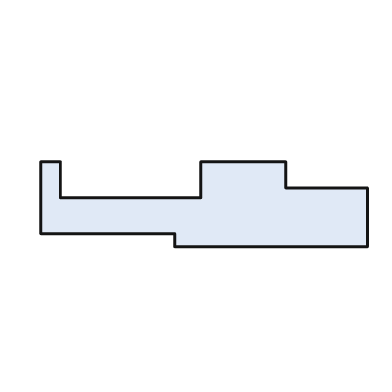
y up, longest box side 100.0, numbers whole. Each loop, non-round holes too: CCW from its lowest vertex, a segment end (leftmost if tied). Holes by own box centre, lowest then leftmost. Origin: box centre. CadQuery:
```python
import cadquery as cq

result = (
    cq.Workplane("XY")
    .moveTo(-9.0, -13.0)
    .lineTo(50.0, -13.0)
    .lineTo(50.0, 5.0)
    .lineTo(25.0, 5.0)
    .lineTo(25.0, 13.0)
    .lineTo(-1.0, 13.0)
    .lineTo(-1.0, 2.0)
    .lineTo(-44.0, 2.0)
    .lineTo(-44.0, 13.0)
    .lineTo(-50.0, 13.0)
    .lineTo(-50.0, -9.0)
    .lineTo(-9.0, -9.0)
    .close()
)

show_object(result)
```